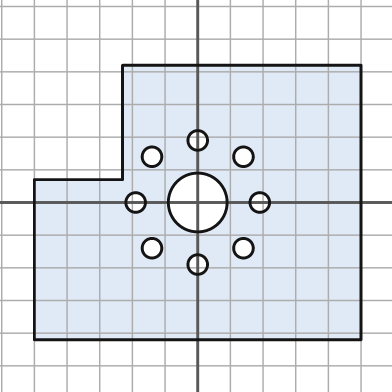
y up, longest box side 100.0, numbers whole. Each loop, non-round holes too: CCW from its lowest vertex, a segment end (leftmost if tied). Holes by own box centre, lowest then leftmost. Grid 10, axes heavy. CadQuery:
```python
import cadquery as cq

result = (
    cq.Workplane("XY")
    .moveTo(-50.0, -42.0)
    .lineTo(50.0, -42.0)
    .lineTo(50.0, 42.0)
    .lineTo(-23.0, 42.0)
    .lineTo(-23.0, 7.0)
    .lineTo(-50.0, 7.0)
    .close()
    .moveTo(0.0, -19.0)
    .circle(3.0)
    .moveTo(-14.0, -14.0)
    .circle(3.0)
    .moveTo(14.0, -14.0)
    .circle(3.0)
    .moveTo(-19.0, 0.0)
    .circle(3.0)
    .moveTo(0.0, 0.0)
    .circle(9.0)
    .moveTo(19.0, 0.0)
    .circle(3.0)
    .moveTo(-14.0, 14.0)
    .circle(3.0)
    .moveTo(14.0, 14.0)
    .circle(3.0)
    .moveTo(0.0, 19.0)
    .circle(3.0)
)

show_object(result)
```